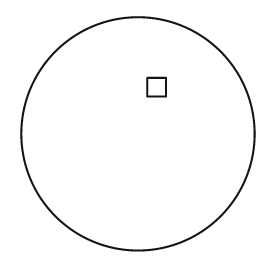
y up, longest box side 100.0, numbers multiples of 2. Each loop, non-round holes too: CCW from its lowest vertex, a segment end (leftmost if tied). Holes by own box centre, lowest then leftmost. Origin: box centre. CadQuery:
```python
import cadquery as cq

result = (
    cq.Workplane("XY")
    .moveTo(0.0, 0.0)
    .circle(50.0)
    .moveTo(4.0, 16.0)
    .lineTo(12.0, 16.0)
    .lineTo(12.0, 24.0)
    .lineTo(4.0, 24.0)
    .close()
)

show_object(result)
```